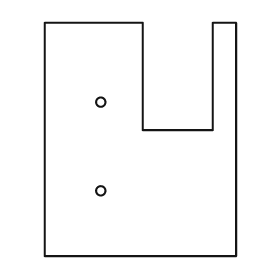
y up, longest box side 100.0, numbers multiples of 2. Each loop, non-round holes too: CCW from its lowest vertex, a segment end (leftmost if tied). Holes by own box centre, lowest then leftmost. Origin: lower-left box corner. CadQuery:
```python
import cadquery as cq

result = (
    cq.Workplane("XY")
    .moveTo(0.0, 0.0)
    .lineTo(82.0, 0.0)
    .lineTo(82.0, 100.0)
    .lineTo(72.0, 100.0)
    .lineTo(72.0, 54.0)
    .lineTo(42.0, 54.0)
    .lineTo(42.0, 100.0)
    .lineTo(0.0, 100.0)
    .close()
    .moveTo(24.0, 28.0)
    .circle(2.0)
    .moveTo(24.0, 66.0)
    .circle(2.0)
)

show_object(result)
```